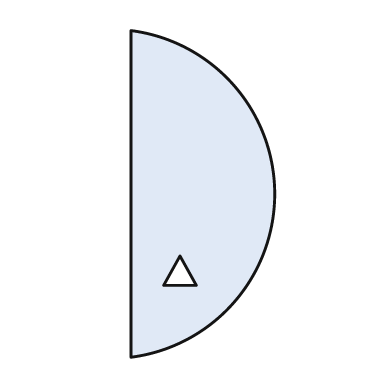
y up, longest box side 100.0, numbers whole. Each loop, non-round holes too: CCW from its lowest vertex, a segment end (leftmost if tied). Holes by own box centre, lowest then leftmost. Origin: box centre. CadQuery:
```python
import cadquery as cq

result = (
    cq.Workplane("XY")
    .moveTo(-22.0, -50.0)
    .threePointArc((22.0, 0.0), (-22.0, 50.0))
    .close()
    .moveTo(-12.0, -28.0)
    .lineTo(-2.0, -28.0)
    .lineTo(-7.0, -19.0)
    .close()
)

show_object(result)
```